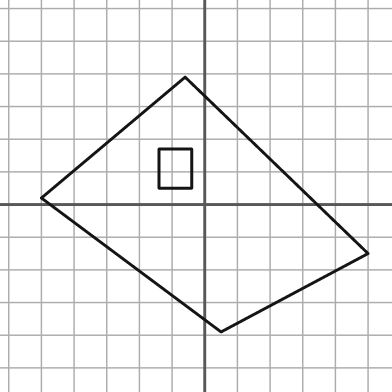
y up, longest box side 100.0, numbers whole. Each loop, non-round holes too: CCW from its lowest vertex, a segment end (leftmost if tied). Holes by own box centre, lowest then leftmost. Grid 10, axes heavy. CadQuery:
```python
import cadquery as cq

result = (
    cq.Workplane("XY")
    .moveTo(5.0, -39.0)
    .lineTo(50.0, -15.0)
    .lineTo(-6.0, 39.0)
    .lineTo(-50.0, 2.0)
    .close()
    .moveTo(-14.0, 5.0)
    .lineTo(-4.0, 5.0)
    .lineTo(-4.0, 17.0)
    .lineTo(-14.0, 17.0)
    .close()
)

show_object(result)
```